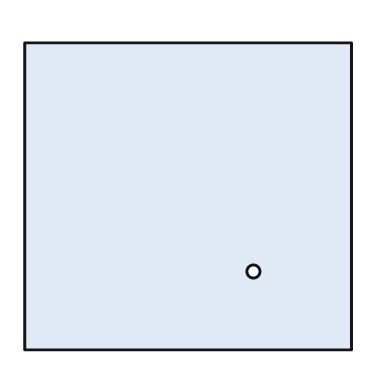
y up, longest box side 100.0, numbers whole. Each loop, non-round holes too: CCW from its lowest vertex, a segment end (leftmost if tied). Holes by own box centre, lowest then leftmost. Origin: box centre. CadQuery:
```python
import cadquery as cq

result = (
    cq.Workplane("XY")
    .moveTo(-50.0, -47.0)
    .lineTo(50.0, -47.0)
    .lineTo(50.0, 47.0)
    .lineTo(-50.0, 47.0)
    .close()
    .moveTo(20.0, -23.0)
    .circle(2.0)
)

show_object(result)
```